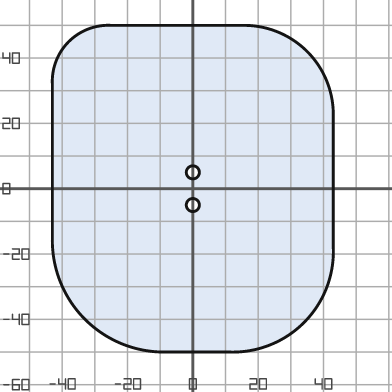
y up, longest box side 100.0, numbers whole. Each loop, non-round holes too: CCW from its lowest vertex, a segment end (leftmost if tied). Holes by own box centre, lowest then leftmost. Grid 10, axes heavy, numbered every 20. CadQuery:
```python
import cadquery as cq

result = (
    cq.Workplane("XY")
    .moveTo(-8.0, -50.0)
    .lineTo(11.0, -50.0)
    .threePointArc((34.0, -41.0), (43.0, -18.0))
    .lineTo(43.0, 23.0)
    .threePointArc((35.0, 42.0), (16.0, 50.0))
    .lineTo(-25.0, 50.0)
    .threePointArc((-38.0, 45.0), (-43.0, 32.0))
    .lineTo(-43.0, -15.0)
    .threePointArc((-33.0, -40.0), (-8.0, -50.0))
    .close()
    .moveTo(0.0, -5.0)
    .circle(2.0)
    .moveTo(0.0, 5.0)
    .circle(2.0)
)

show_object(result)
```